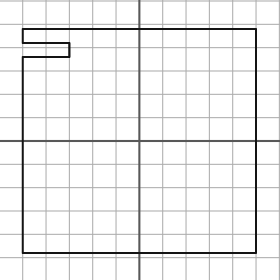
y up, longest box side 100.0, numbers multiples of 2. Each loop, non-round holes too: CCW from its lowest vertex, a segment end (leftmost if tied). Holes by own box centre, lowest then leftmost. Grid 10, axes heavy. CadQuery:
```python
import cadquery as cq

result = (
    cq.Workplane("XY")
    .moveTo(-50.0, -48.0)
    .lineTo(50.0, -48.0)
    .lineTo(50.0, 48.0)
    .lineTo(-50.0, 48.0)
    .lineTo(-50.0, 42.0)
    .lineTo(-30.0, 42.0)
    .lineTo(-30.0, 36.0)
    .lineTo(-50.0, 36.0)
    .close()
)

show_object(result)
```